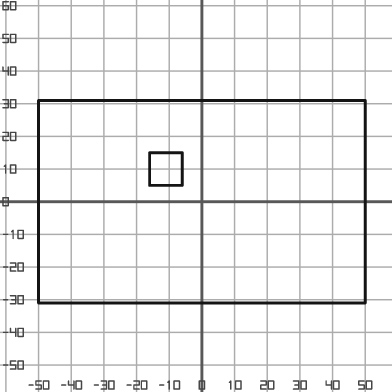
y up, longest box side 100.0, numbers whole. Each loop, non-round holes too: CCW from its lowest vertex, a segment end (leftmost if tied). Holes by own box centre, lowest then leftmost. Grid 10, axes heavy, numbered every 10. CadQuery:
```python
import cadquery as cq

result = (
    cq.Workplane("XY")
    .moveTo(-50.0, -31.0)
    .lineTo(50.0, -31.0)
    .lineTo(50.0, 31.0)
    .lineTo(-50.0, 31.0)
    .close()
    .moveTo(-16.0, 5.0)
    .lineTo(-6.0, 5.0)
    .lineTo(-6.0, 15.0)
    .lineTo(-16.0, 15.0)
    .close()
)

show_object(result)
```